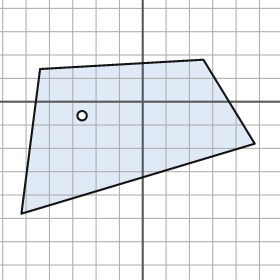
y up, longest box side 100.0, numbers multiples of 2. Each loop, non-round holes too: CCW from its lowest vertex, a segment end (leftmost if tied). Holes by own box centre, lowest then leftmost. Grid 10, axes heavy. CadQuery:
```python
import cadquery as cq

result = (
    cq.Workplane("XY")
    .moveTo(-52.0, -48.0)
    .lineTo(48.0, -18.0)
    .lineTo(26.0, 18.0)
    .lineTo(-44.0, 14.0)
    .close()
    .moveTo(-26.0, -6.0)
    .circle(2.0)
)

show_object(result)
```